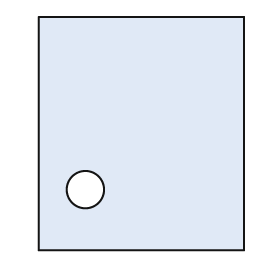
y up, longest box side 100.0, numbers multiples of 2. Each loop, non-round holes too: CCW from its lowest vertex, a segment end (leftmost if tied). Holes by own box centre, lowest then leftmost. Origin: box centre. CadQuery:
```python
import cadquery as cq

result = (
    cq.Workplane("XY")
    .moveTo(-44.0, -50.0)
    .lineTo(44.0, -50.0)
    .lineTo(44.0, 50.0)
    .lineTo(-44.0, 50.0)
    .close()
    .moveTo(-24.0, -24.0)
    .circle(8.0)
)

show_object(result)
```